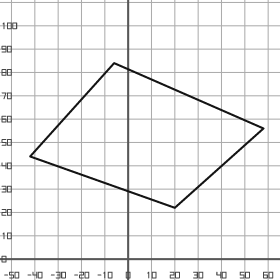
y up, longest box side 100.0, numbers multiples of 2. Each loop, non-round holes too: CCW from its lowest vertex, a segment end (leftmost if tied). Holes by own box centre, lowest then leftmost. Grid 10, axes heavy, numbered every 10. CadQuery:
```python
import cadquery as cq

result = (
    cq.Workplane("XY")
    .moveTo(20.0, 22.0)
    .lineTo(58.0, 56.0)
    .lineTo(-6.0, 84.0)
    .lineTo(-42.0, 44.0)
    .close()
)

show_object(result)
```